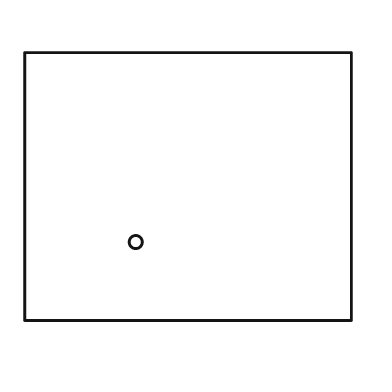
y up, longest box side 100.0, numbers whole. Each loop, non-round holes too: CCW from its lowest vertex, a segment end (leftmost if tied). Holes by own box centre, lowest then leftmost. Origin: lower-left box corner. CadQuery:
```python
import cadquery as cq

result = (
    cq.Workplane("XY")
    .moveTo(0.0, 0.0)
    .lineTo(100.0, 0.0)
    .lineTo(100.0, 82.0)
    .lineTo(0.0, 82.0)
    .close()
    .moveTo(34.0, 24.0)
    .circle(2.0)
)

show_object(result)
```